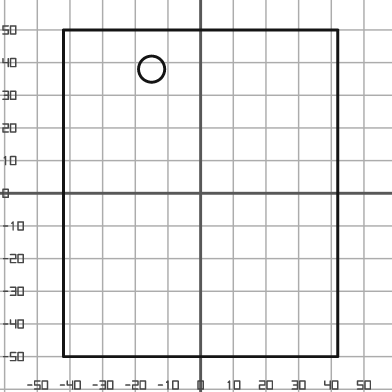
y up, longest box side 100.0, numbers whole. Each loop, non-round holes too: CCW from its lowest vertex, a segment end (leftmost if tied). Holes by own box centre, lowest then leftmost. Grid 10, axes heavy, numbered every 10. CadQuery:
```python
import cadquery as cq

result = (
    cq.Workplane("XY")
    .moveTo(-42.0, -50.0)
    .lineTo(42.0, -50.0)
    .lineTo(42.0, 50.0)
    .lineTo(-42.0, 50.0)
    .close()
    .moveTo(-15.0, 38.0)
    .circle(4.0)
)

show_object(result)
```